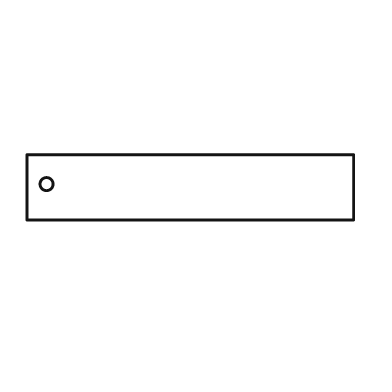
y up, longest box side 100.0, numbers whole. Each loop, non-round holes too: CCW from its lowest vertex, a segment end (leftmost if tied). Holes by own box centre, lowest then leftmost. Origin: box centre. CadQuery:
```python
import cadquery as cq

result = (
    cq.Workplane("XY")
    .moveTo(-50.0, -10.0)
    .lineTo(50.0, -10.0)
    .lineTo(50.0, 10.0)
    .lineTo(-50.0, 10.0)
    .close()
    .moveTo(-44.0, 1.0)
    .circle(2.0)
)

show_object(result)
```